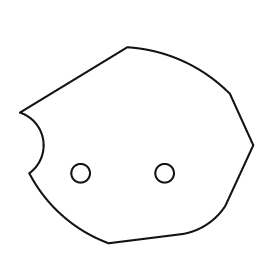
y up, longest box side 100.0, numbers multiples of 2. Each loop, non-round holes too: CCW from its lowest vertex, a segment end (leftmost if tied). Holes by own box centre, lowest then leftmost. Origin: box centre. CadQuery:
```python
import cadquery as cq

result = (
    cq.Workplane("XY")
    .moveTo(-12.0, -42.0)
    .lineTo(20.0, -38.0)
    .threePointArc((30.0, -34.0), (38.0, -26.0))
    .lineTo(50.0, 0.0)
    .lineTo(40.0, 22.0)
    .threePointArc((20.0, 36.0), (-4.0, 42.0))
    .lineTo(-50.0, 14.0)
    .threePointArc((-40.0, 2.0), (-46.0, -12.0))
    .threePointArc((-32.0, -30.0), (-12.0, -42.0))
    .close()
    .moveTo(-24.0, -12.0)
    .circle(4.0)
    .moveTo(12.0, -12.0)
    .circle(4.0)
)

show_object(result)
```